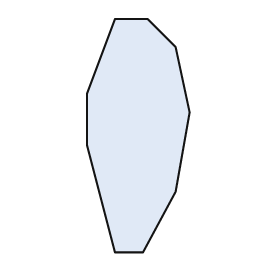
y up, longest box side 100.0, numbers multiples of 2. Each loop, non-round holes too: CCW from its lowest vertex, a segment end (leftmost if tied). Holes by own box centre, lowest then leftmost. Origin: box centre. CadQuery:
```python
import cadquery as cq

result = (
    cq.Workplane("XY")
    .moveTo(-10.0, -50.0)
    .lineTo(2.0, -50.0)
    .lineTo(16.0, -24.0)
    .lineTo(22.0, 10.0)
    .lineTo(16.0, 38.0)
    .lineTo(4.0, 50.0)
    .lineTo(-10.0, 50.0)
    .lineTo(-22.0, 18.0)
    .lineTo(-22.0, -4.0)
    .close()
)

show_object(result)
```